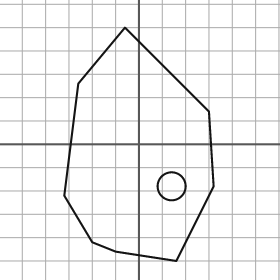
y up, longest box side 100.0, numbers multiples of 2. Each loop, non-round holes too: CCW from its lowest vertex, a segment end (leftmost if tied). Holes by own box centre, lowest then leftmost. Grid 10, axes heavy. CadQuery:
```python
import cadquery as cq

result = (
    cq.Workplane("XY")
    .moveTo(16.0, -50.0)
    .lineTo(32.0, -18.0)
    .lineTo(30.0, 14.0)
    .lineTo(-6.0, 50.0)
    .lineTo(-26.0, 26.0)
    .lineTo(-32.0, -22.0)
    .lineTo(-20.0, -42.0)
    .lineTo(-10.0, -46.0)
    .close()
    .moveTo(14.0, -18.0)
    .circle(6.0)
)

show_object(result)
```